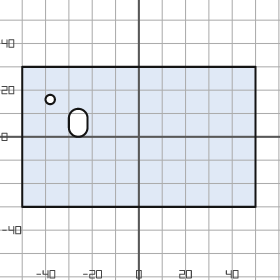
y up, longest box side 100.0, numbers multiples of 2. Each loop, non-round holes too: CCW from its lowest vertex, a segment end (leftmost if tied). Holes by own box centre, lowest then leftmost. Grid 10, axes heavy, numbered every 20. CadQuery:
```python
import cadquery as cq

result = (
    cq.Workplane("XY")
    .moveTo(-50.0, -30.0)
    .lineTo(50.0, -30.0)
    .lineTo(50.0, 30.0)
    .lineTo(-50.0, 30.0)
    .close()
    .moveTo(-30.0, 4.0)
    .threePointArc((-26.0, 0.0), (-22.0, 4.0))
    .lineTo(-22.0, 8.0)
    .threePointArc((-26.0, 12.0), (-30.0, 8.0))
    .close()
    .moveTo(-38.0, 16.0)
    .circle(2.0)
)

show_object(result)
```